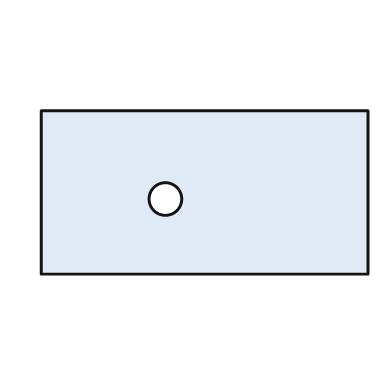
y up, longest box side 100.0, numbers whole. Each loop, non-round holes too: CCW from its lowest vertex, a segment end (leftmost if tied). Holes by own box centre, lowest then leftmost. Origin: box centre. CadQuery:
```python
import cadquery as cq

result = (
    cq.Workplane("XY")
    .moveTo(-50.0, -25.0)
    .lineTo(50.0, -25.0)
    .lineTo(50.0, 25.0)
    .lineTo(-50.0, 25.0)
    .close()
    .moveTo(-12.0, -2.0)
    .circle(5.0)
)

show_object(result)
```